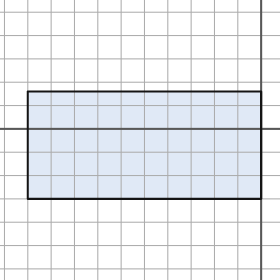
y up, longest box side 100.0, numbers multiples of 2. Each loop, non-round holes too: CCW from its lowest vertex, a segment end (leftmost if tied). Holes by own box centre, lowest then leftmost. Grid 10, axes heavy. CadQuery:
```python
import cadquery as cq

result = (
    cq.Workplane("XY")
    .moveTo(-100.0, -30.0)
    .lineTo(0.0, -30.0)
    .lineTo(0.0, 16.0)
    .lineTo(-100.0, 16.0)
    .close()
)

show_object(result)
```